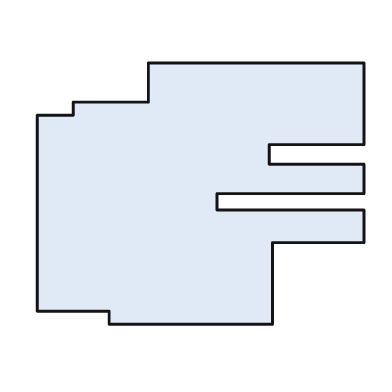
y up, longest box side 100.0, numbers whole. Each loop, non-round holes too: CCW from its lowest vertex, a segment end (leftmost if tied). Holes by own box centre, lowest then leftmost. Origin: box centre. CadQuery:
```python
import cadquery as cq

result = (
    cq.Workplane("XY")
    .moveTo(-28.0, -40.0)
    .lineTo(22.0, -40.0)
    .lineTo(22.0, -15.0)
    .lineTo(50.0, -15.0)
    .lineTo(50.0, -5.0)
    .lineTo(5.0, -5.0)
    .lineTo(5.0, 0.0)
    .lineTo(50.0, 0.0)
    .lineTo(50.0, 9.0)
    .lineTo(21.0, 9.0)
    .lineTo(21.0, 15.0)
    .lineTo(50.0, 15.0)
    .lineTo(50.0, 40.0)
    .lineTo(-16.0, 40.0)
    .lineTo(-16.0, 28.0)
    .lineTo(-39.0, 28.0)
    .lineTo(-39.0, 24.0)
    .lineTo(-50.0, 24.0)
    .lineTo(-50.0, -36.0)
    .lineTo(-28.0, -36.0)
    .close()
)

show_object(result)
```